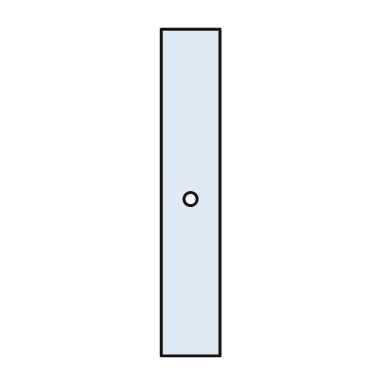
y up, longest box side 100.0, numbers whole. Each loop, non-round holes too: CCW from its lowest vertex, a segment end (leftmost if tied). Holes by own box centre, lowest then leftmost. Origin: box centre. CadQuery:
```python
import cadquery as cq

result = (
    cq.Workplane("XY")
    .moveTo(-9.0, -50.0)
    .lineTo(9.0, -50.0)
    .lineTo(9.0, 50.0)
    .lineTo(-9.0, 50.0)
    .close()
    .moveTo(0.0, -2.0)
    .circle(2.0)
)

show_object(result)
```